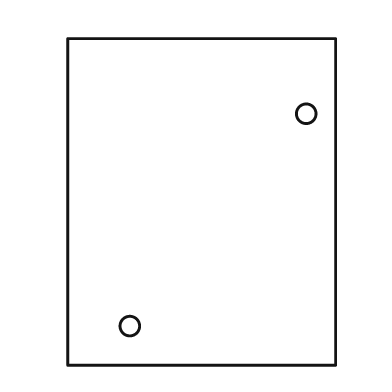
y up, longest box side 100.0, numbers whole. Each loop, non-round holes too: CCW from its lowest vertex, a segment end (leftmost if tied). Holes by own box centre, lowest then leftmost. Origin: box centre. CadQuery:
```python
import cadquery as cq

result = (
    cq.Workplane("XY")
    .moveTo(-41.0, -50.0)
    .lineTo(41.0, -50.0)
    .lineTo(41.0, 50.0)
    .lineTo(-41.0, 50.0)
    .close()
    .moveTo(-22.0, -38.0)
    .circle(3.0)
    .moveTo(32.0, 27.0)
    .circle(3.0)
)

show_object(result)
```